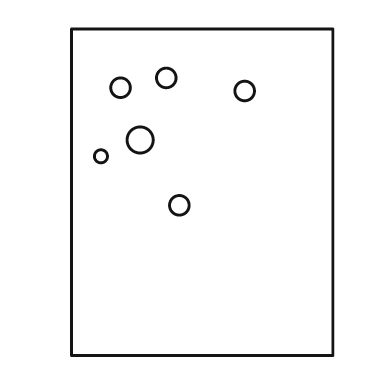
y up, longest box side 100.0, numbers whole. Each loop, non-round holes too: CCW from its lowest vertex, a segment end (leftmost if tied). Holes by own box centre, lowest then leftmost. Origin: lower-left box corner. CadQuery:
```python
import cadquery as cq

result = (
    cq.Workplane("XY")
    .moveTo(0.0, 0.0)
    .lineTo(80.0, 0.0)
    .lineTo(80.0, 100.0)
    .lineTo(0.0, 100.0)
    .close()
    .moveTo(33.0, 46.0)
    .circle(3.0)
    .moveTo(9.0, 61.0)
    .circle(2.0)
    .moveTo(21.0, 66.0)
    .circle(4.0)
    .moveTo(53.0, 81.0)
    .circle(3.0)
    .moveTo(15.0, 82.0)
    .circle(3.0)
    .moveTo(29.0, 85.0)
    .circle(3.0)
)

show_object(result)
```